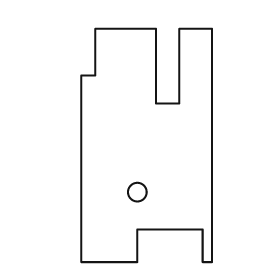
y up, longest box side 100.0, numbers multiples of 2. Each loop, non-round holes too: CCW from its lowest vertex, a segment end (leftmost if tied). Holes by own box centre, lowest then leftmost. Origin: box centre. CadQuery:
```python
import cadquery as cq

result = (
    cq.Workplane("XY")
    .moveTo(-28.0, -50.0)
    .lineTo(-4.0, -50.0)
    .lineTo(-4.0, -36.0)
    .lineTo(24.0, -36.0)
    .lineTo(24.0, -50.0)
    .lineTo(28.0, -50.0)
    .lineTo(28.0, 50.0)
    .lineTo(14.0, 50.0)
    .lineTo(14.0, 18.0)
    .lineTo(4.0, 18.0)
    .lineTo(4.0, 50.0)
    .lineTo(-22.0, 50.0)
    .lineTo(-22.0, 30.0)
    .lineTo(-28.0, 30.0)
    .close()
    .moveTo(-4.0, -20.0)
    .circle(4.0)
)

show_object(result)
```